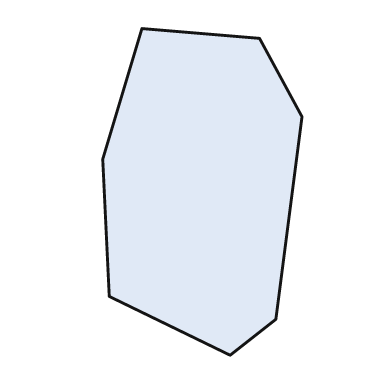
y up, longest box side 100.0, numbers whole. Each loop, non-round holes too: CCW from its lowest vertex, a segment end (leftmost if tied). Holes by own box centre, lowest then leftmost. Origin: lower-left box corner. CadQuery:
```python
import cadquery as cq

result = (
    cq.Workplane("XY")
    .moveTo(39.0, 0.0)
    .lineTo(53.0, 11.0)
    .lineTo(61.0, 73.0)
    .lineTo(48.0, 97.0)
    .lineTo(12.0, 100.0)
    .lineTo(0.0, 60.0)
    .lineTo(2.0, 18.0)
    .close()
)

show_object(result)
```